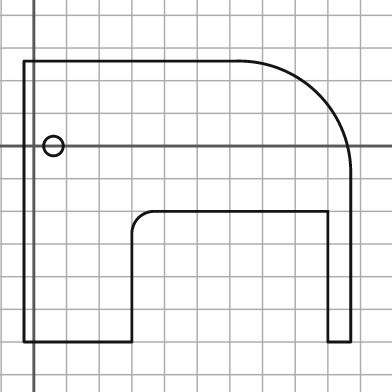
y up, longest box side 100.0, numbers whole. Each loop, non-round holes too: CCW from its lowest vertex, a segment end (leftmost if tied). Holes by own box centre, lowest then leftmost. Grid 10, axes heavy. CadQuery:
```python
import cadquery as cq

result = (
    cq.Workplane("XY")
    .moveTo(-3.0, -60.0)
    .lineTo(30.0, -60.0)
    .lineTo(30.0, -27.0)
    .threePointArc((32.0, -22.0), (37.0, -20.0))
    .lineTo(90.0, -20.0)
    .lineTo(90.0, -60.0)
    .lineTo(97.0, -60.0)
    .lineTo(97.0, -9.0)
    .threePointArc((87.0, 16.0), (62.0, 26.0))
    .lineTo(-3.0, 26.0)
    .close()
    .moveTo(6.0, 0.0)
    .circle(3.0)
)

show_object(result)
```